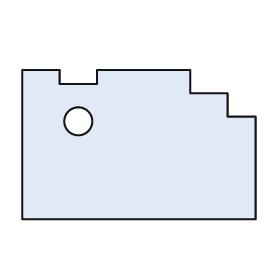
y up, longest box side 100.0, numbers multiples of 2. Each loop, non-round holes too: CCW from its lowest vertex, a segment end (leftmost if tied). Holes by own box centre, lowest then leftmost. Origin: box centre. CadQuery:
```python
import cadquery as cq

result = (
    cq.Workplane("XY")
    .moveTo(-50.0, -32.0)
    .lineTo(50.0, -32.0)
    .lineTo(50.0, 12.0)
    .lineTo(38.0, 12.0)
    .lineTo(38.0, 22.0)
    .lineTo(22.0, 22.0)
    .lineTo(22.0, 32.0)
    .lineTo(-18.0, 32.0)
    .lineTo(-18.0, 26.0)
    .lineTo(-34.0, 26.0)
    .lineTo(-34.0, 32.0)
    .lineTo(-50.0, 32.0)
    .close()
    .moveTo(-26.0, 10.0)
    .circle(6.0)
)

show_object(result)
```